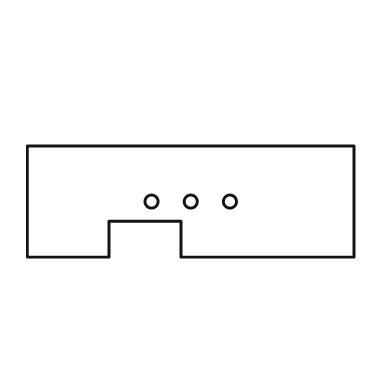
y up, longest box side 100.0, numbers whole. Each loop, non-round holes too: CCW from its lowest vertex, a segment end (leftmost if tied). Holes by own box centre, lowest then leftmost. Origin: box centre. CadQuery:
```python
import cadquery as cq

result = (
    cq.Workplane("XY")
    .moveTo(-50.0, -17.0)
    .lineTo(-25.0, -17.0)
    .lineTo(-25.0, -6.0)
    .lineTo(-3.0, -6.0)
    .lineTo(-3.0, -17.0)
    .lineTo(50.0, -17.0)
    .lineTo(50.0, 17.0)
    .lineTo(-50.0, 17.0)
    .close()
    .moveTo(-12.0, 0.0)
    .circle(2.0)
    .moveTo(0.0, 0.0)
    .circle(2.0)
    .moveTo(12.0, 0.0)
    .circle(2.0)
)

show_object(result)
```